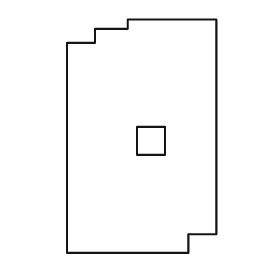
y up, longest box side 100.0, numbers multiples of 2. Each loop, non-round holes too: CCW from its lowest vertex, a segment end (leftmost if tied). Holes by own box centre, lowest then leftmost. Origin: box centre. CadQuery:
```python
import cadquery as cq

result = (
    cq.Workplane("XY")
    .moveTo(-32.0, -50.0)
    .lineTo(20.0, -50.0)
    .lineTo(20.0, -42.0)
    .lineTo(32.0, -42.0)
    .lineTo(32.0, 50.0)
    .lineTo(-6.0, 50.0)
    .lineTo(-6.0, 46.0)
    .lineTo(-20.0, 46.0)
    .lineTo(-20.0, 40.0)
    .lineTo(-32.0, 40.0)
    .close()
    .moveTo(-2.0, -8.0)
    .lineTo(10.0, -8.0)
    .lineTo(10.0, 4.0)
    .lineTo(-2.0, 4.0)
    .close()
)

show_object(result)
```